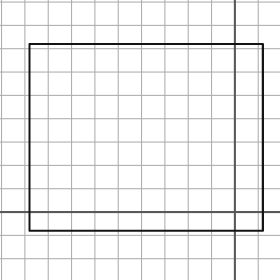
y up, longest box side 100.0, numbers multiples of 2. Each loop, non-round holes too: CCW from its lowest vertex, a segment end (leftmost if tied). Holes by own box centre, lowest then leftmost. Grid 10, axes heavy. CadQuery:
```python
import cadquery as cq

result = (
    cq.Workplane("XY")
    .moveTo(-88.0, -8.0)
    .lineTo(12.0, -8.0)
    .lineTo(12.0, 72.0)
    .lineTo(-88.0, 72.0)
    .close()
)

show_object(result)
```